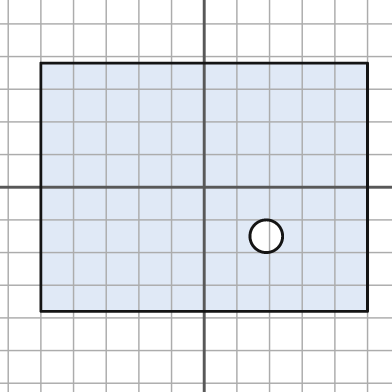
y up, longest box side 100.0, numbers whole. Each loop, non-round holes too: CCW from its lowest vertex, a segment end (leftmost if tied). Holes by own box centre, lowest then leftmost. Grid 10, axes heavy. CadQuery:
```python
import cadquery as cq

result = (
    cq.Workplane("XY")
    .moveTo(-50.0, -38.0)
    .lineTo(50.0, -38.0)
    .lineTo(50.0, 38.0)
    .lineTo(-50.0, 38.0)
    .close()
    .moveTo(19.0, -15.0)
    .circle(5.0)
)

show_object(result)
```